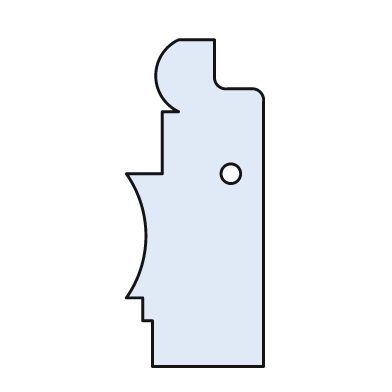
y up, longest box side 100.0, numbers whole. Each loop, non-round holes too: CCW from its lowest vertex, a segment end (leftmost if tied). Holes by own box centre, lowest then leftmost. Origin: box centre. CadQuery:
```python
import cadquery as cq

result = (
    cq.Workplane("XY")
    .moveTo(-13.0, -50.0)
    .lineTo(21.0, -50.0)
    .lineTo(21.0, 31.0)
    .threePointArc((20.0, 34.0), (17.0, 35.0))
    .lineTo(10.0, 35.0)
    .threePointArc((7.0, 36.0), (6.0, 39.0))
    .lineTo(6.0, 50.0)
    .lineTo(-5.0, 50.0)
    .threePointArc((-12.0, 39.0), (-5.0, 28.0))
    .lineTo(-10.0, 28.0)
    .lineTo(-10.0, 9.0)
    .lineTo(-21.0, 9.0)
    .threePointArc((-15.0, -10.0), (-21.0, -29.0))
    .lineTo(-16.0, -29.0)
    .lineTo(-16.0, -36.0)
    .lineTo(-13.0, -36.0)
    .close()
    .moveTo(11.0, 9.0)
    .circle(3.0)
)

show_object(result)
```